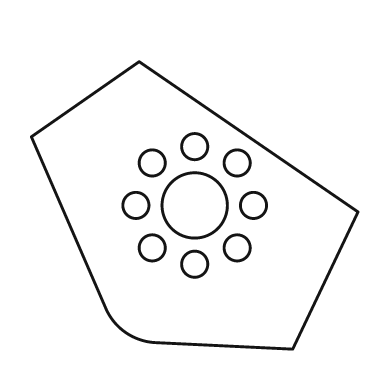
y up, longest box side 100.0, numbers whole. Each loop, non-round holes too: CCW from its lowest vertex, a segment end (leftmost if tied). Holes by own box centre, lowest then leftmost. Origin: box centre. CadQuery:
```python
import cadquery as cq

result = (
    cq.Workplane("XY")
    .moveTo(30.0, -44.0)
    .lineTo(50.0, -2.0)
    .lineTo(-17.0, 44.0)
    .lineTo(-50.0, 21.0)
    .lineTo(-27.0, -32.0)
    .threePointArc((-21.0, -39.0), (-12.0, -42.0))
    .close()
    .moveTo(0.0, -18.0)
    .circle(4.0)
    .moveTo(-13.0, -13.0)
    .circle(4.0)
    .moveTo(13.0, -13.0)
    .circle(4.0)
    .moveTo(-18.0, 0.0)
    .circle(4.0)
    .moveTo(0.0, 0.0)
    .circle(10.0)
    .moveTo(18.0, 0.0)
    .circle(4.0)
    .moveTo(-13.0, 13.0)
    .circle(4.0)
    .moveTo(13.0, 13.0)
    .circle(4.0)
    .moveTo(0.0, 18.0)
    .circle(4.0)
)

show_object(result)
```